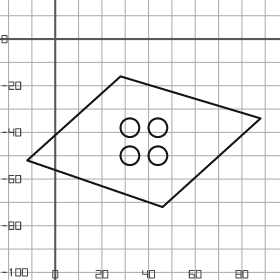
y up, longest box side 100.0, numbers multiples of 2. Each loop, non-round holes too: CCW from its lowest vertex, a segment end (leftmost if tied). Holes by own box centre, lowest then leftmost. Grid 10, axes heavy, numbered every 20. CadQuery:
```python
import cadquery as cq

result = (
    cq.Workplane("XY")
    .moveTo(46.0, -72.0)
    .lineTo(88.0, -34.0)
    .lineTo(28.0, -16.0)
    .lineTo(-12.0, -52.0)
    .close()
    .moveTo(32.0, -50.0)
    .circle(4.0)
    .moveTo(44.0, -50.0)
    .circle(4.0)
    .moveTo(32.0, -38.0)
    .circle(4.0)
    .moveTo(44.0, -38.0)
    .circle(4.0)
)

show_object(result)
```